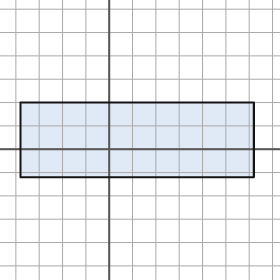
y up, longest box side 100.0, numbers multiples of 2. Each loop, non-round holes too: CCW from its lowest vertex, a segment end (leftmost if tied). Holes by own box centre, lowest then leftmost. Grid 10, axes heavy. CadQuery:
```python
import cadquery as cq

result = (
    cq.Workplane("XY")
    .moveTo(-38.0, -12.0)
    .lineTo(62.0, -12.0)
    .lineTo(62.0, 20.0)
    .lineTo(-38.0, 20.0)
    .close()
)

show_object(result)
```